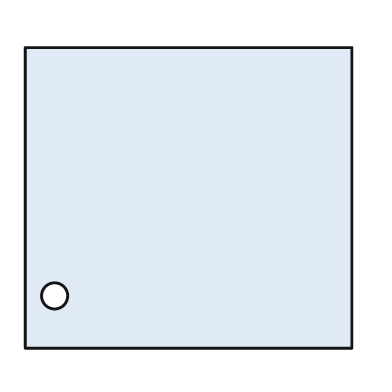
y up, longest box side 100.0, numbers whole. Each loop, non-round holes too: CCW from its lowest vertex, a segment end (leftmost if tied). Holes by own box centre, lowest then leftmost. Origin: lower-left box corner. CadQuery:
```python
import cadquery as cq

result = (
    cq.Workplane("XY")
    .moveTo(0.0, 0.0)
    .lineTo(100.0, 0.0)
    .lineTo(100.0, 92.0)
    .lineTo(0.0, 92.0)
    .close()
    .moveTo(9.0, 16.0)
    .circle(4.0)
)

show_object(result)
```